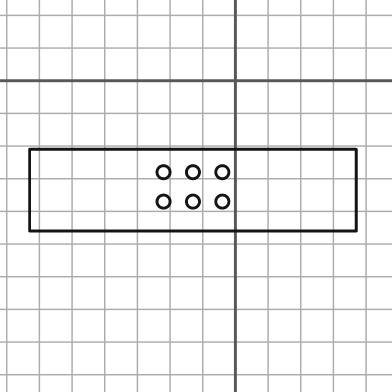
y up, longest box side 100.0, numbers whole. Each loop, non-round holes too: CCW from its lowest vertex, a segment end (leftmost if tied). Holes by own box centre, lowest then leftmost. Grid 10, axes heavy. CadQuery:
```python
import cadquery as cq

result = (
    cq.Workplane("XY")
    .moveTo(-63.0, -46.0)
    .lineTo(37.0, -46.0)
    .lineTo(37.0, -21.0)
    .lineTo(-63.0, -21.0)
    .close()
    .moveTo(-22.0, -37.0)
    .circle(2.0)
    .moveTo(-13.0, -37.0)
    .circle(2.0)
    .moveTo(-4.0, -37.0)
    .circle(2.0)
    .moveTo(-22.0, -28.0)
    .circle(2.0)
    .moveTo(-13.0, -28.0)
    .circle(2.0)
    .moveTo(-4.0, -28.0)
    .circle(2.0)
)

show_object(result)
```